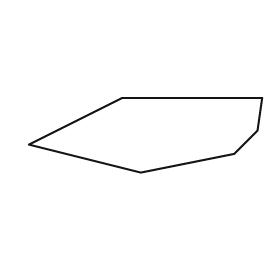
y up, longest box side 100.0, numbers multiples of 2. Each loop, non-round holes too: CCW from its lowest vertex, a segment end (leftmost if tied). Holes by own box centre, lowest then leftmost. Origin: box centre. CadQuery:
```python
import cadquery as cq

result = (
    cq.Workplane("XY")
    .moveTo(-2.0, -16.0)
    .lineTo(38.0, -8.0)
    .lineTo(48.0, 2.0)
    .lineTo(50.0, 16.0)
    .lineTo(-10.0, 16.0)
    .lineTo(-50.0, -4.0)
    .close()
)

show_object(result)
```